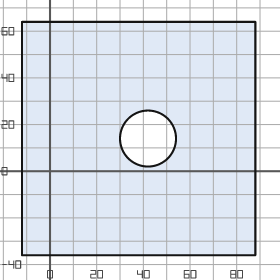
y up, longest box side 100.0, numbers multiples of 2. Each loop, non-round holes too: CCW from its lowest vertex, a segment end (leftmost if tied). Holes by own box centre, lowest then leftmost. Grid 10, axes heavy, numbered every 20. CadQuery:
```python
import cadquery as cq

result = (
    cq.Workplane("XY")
    .moveTo(-12.0, -36.0)
    .lineTo(88.0, -36.0)
    .lineTo(88.0, 64.0)
    .lineTo(-12.0, 64.0)
    .close()
    .moveTo(42.0, 14.0)
    .circle(12.0)
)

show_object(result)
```